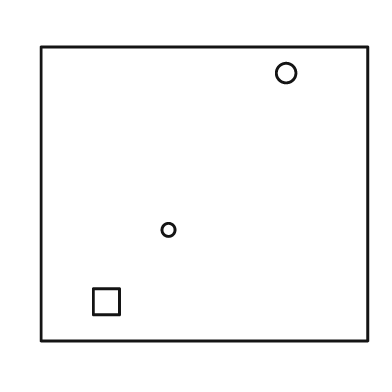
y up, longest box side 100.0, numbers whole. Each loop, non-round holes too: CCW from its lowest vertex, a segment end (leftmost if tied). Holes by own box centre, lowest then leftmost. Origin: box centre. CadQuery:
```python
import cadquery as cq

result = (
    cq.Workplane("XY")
    .moveTo(-50.0, -45.0)
    .lineTo(50.0, -45.0)
    .lineTo(50.0, 45.0)
    .lineTo(-50.0, 45.0)
    .close()
    .moveTo(-34.0, -37.0)
    .lineTo(-26.0, -37.0)
    .lineTo(-26.0, -29.0)
    .lineTo(-34.0, -29.0)
    .close()
    .moveTo(-11.0, -11.0)
    .circle(2.0)
    .moveTo(25.0, 37.0)
    .circle(3.0)
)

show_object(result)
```